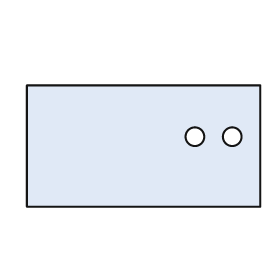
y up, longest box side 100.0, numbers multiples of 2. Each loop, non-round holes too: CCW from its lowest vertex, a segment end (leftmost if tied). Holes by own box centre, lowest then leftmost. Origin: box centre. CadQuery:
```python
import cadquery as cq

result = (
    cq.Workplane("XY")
    .moveTo(-50.0, -26.0)
    .lineTo(50.0, -26.0)
    .lineTo(50.0, 26.0)
    .lineTo(-50.0, 26.0)
    .close()
    .moveTo(22.0, 4.0)
    .circle(4.0)
    .moveTo(38.0, 4.0)
    .circle(4.0)
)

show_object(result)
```